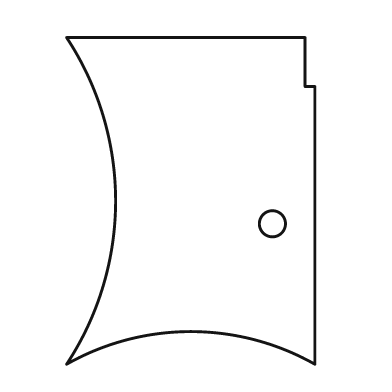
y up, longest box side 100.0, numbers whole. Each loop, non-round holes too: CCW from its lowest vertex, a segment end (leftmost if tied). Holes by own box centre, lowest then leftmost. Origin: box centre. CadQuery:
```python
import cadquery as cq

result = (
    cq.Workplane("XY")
    .moveTo(-38.0, -50.0)
    .threePointArc((0.0, -40.0), (38.0, -50.0))
    .lineTo(38.0, 35.0)
    .lineTo(35.0, 35.0)
    .lineTo(35.0, 50.0)
    .lineTo(-38.0, 50.0)
    .threePointArc((-23.0, 0.0), (-38.0, -50.0))
    .close()
    .moveTo(25.0, -7.0)
    .circle(4.0)
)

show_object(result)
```